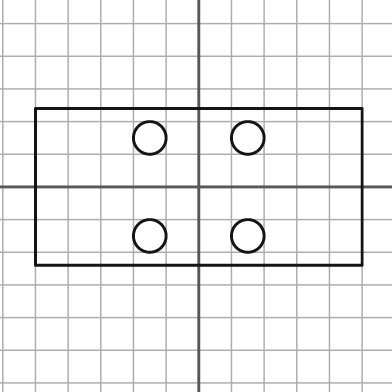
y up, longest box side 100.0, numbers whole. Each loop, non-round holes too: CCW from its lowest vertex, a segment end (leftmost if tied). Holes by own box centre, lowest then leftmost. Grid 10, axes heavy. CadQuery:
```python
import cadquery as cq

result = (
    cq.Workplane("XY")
    .moveTo(-50.0, -24.0)
    .lineTo(50.0, -24.0)
    .lineTo(50.0, 24.0)
    .lineTo(-50.0, 24.0)
    .close()
    .moveTo(-15.0, -15.0)
    .circle(5.0)
    .moveTo(15.0, -15.0)
    .circle(5.0)
    .moveTo(-15.0, 15.0)
    .circle(5.0)
    .moveTo(15.0, 15.0)
    .circle(5.0)
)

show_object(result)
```